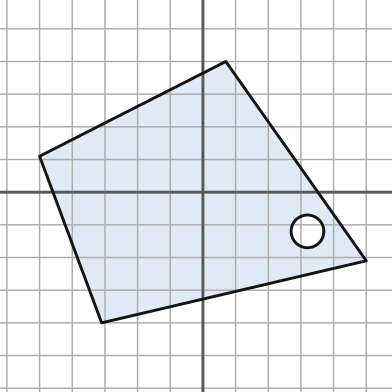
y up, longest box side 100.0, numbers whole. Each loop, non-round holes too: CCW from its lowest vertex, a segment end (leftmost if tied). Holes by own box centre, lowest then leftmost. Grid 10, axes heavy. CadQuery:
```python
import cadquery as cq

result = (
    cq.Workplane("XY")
    .moveTo(-31.0, -40.0)
    .lineTo(50.0, -21.0)
    .lineTo(7.0, 40.0)
    .lineTo(-50.0, 11.0)
    .close()
    .moveTo(32.0, -12.0)
    .circle(5.0)
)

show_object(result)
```